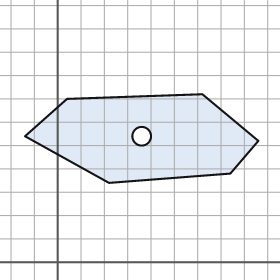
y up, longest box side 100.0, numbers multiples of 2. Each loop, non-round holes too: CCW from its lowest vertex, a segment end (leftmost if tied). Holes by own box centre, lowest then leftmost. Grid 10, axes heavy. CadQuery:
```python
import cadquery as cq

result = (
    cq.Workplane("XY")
    .moveTo(22.0, 34.0)
    .lineTo(74.0, 38.0)
    .lineTo(86.0, 52.0)
    .lineTo(62.0, 72.0)
    .lineTo(4.0, 70.0)
    .lineTo(-14.0, 54.0)
    .close()
    .moveTo(36.0, 54.0)
    .circle(4.0)
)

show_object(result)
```